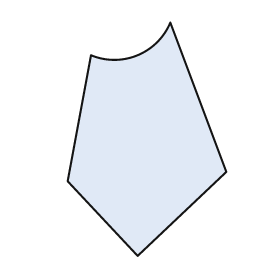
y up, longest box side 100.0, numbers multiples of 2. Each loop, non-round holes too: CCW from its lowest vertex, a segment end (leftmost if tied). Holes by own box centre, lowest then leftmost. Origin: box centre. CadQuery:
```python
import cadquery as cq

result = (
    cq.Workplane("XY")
    .moveTo(-4.0, -50.0)
    .lineTo(34.0, -14.0)
    .lineTo(10.0, 50.0)
    .threePointArc((-4.0, 36.0), (-24.0, 36.0))
    .lineTo(-34.0, -18.0)
    .close()
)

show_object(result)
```